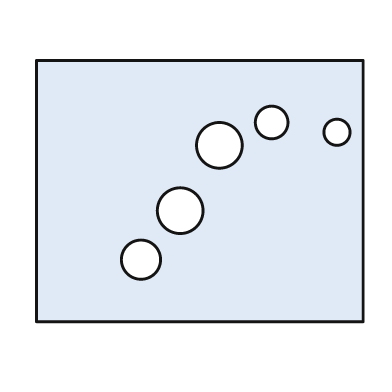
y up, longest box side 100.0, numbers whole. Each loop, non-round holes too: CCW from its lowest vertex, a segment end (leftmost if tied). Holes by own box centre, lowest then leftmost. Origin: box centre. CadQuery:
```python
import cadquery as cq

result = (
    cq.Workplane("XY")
    .moveTo(-50.0, -40.0)
    .lineTo(50.0, -40.0)
    .lineTo(50.0, 40.0)
    .lineTo(-50.0, 40.0)
    .close()
    .moveTo(-18.0, -21.0)
    .circle(6.0)
    .moveTo(-6.0, -6.0)
    .circle(7.0)
    .moveTo(6.0, 14.0)
    .circle(7.0)
    .moveTo(42.0, 18.0)
    .circle(4.0)
    .moveTo(22.0, 21.0)
    .circle(5.0)
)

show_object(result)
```